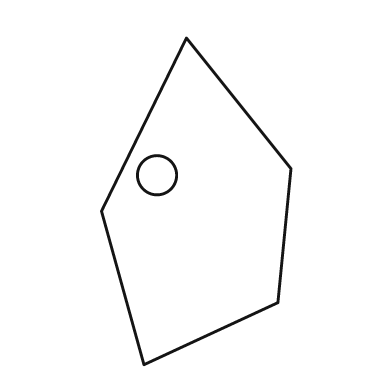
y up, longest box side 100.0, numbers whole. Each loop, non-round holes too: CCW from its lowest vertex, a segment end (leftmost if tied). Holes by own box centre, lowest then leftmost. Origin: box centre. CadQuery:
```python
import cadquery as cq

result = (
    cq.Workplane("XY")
    .moveTo(-16.0, -50.0)
    .lineTo(25.0, -31.0)
    .lineTo(29.0, 10.0)
    .lineTo(-3.0, 50.0)
    .lineTo(-29.0, -3.0)
    .close()
    .moveTo(-12.0, 8.0)
    .circle(6.0)
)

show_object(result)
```